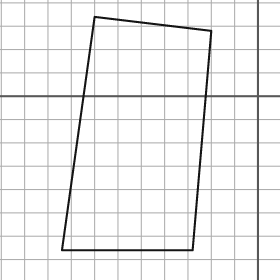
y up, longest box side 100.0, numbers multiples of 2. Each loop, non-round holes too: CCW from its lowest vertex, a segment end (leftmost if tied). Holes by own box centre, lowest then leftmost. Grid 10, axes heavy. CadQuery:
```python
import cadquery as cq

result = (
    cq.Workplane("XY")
    .moveTo(-84.0, -66.0)
    .lineTo(-28.0, -66.0)
    .lineTo(-20.0, 28.0)
    .lineTo(-70.0, 34.0)
    .close()
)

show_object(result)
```